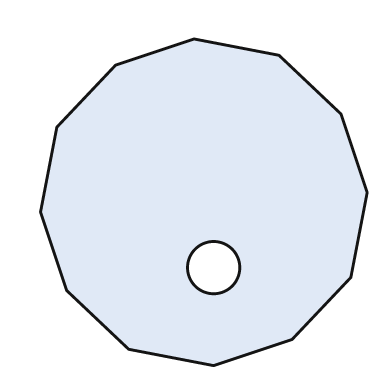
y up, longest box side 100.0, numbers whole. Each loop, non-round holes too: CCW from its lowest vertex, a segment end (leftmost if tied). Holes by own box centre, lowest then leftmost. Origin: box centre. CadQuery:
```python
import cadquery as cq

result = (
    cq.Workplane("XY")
    .moveTo(3.0, -50.0)
    .lineTo(27.0, -42.0)
    .lineTo(45.0, -23.0)
    .lineTo(50.0, 3.0)
    .lineTo(42.0, 27.0)
    .lineTo(23.0, 45.0)
    .lineTo(-3.0, 50.0)
    .lineTo(-27.0, 42.0)
    .lineTo(-45.0, 23.0)
    .lineTo(-50.0, -3.0)
    .lineTo(-42.0, -27.0)
    .lineTo(-23.0, -45.0)
    .close()
    .moveTo(3.0, -20.0)
    .circle(8.0)
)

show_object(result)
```